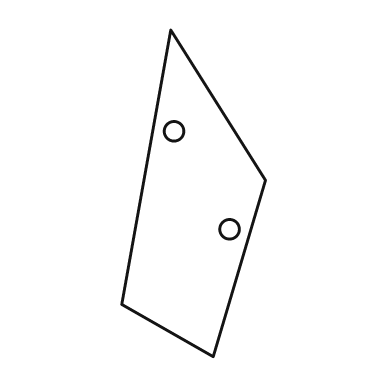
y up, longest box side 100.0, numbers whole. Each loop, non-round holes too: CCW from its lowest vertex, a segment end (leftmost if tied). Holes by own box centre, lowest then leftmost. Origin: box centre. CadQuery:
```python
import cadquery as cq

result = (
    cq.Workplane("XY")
    .moveTo(6.0, -50.0)
    .lineTo(22.0, 4.0)
    .lineTo(-7.0, 50.0)
    .lineTo(-22.0, -34.0)
    .close()
    .moveTo(11.0, -11.0)
    .circle(3.0)
    .moveTo(-6.0, 19.0)
    .circle(3.0)
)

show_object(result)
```